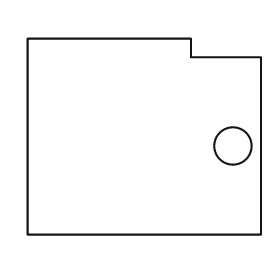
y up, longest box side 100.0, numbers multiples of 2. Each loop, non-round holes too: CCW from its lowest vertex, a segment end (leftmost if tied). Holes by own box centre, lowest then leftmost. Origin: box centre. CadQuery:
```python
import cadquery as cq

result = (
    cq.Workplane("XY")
    .moveTo(-50.0, -42.0)
    .lineTo(50.0, -42.0)
    .lineTo(50.0, 34.0)
    .lineTo(20.0, 34.0)
    .lineTo(20.0, 42.0)
    .lineTo(-50.0, 42.0)
    .close()
    .moveTo(38.0, -4.0)
    .circle(8.0)
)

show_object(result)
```